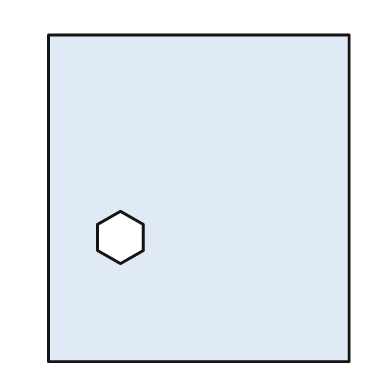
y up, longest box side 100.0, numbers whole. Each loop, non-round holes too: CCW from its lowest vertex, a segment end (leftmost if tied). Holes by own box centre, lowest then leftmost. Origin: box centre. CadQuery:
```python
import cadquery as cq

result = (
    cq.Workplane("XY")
    .moveTo(-46.0, -50.0)
    .lineTo(46.0, -50.0)
    .lineTo(46.0, 50.0)
    .lineTo(-46.0, 50.0)
    .close()
    .moveTo(-24.0, -20.0)
    .lineTo(-17.0, -16.0)
    .lineTo(-17.0, -8.0)
    .lineTo(-24.0, -4.0)
    .lineTo(-31.0, -8.0)
    .lineTo(-31.0, -16.0)
    .close()
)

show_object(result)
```